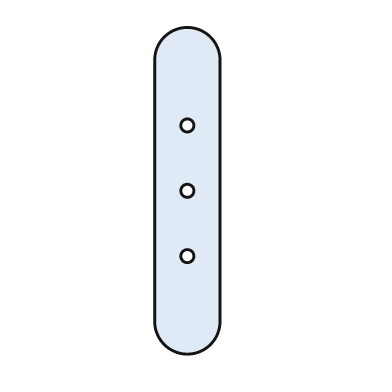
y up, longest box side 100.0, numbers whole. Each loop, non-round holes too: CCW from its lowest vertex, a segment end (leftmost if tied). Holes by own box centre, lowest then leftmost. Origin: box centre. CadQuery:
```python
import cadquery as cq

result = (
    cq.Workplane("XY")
    .moveTo(-10.0, -40.0)
    .threePointArc((0.0, -50.0), (10.0, -40.0))
    .lineTo(10.0, 40.0)
    .threePointArc((0.0, 50.0), (-10.0, 40.0))
    .close()
    .moveTo(0.0, -20.0)
    .circle(2.0)
    .moveTo(0.0, 0.0)
    .circle(2.0)
    .moveTo(0.0, 20.0)
    .circle(2.0)
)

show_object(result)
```